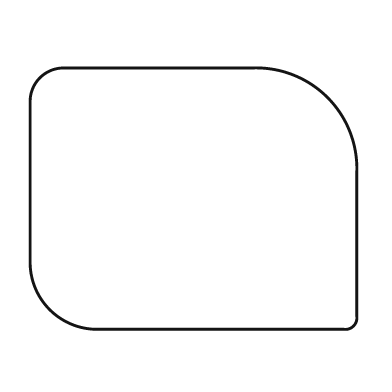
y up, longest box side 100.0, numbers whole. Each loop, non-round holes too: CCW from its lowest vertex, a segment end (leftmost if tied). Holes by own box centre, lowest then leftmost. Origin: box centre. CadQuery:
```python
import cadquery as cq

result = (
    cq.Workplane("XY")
    .moveTo(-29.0, -40.0)
    .lineTo(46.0, -40.0)
    .threePointArc((49.0, -39.0), (50.0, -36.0))
    .lineTo(50.0, 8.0)
    .threePointArc((41.0, 31.0), (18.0, 40.0))
    .lineTo(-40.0, 40.0)
    .threePointArc((-47.0, 37.0), (-50.0, 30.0))
    .lineTo(-50.0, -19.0)
    .threePointArc((-44.0, -34.0), (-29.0, -40.0))
    .close()
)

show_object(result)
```